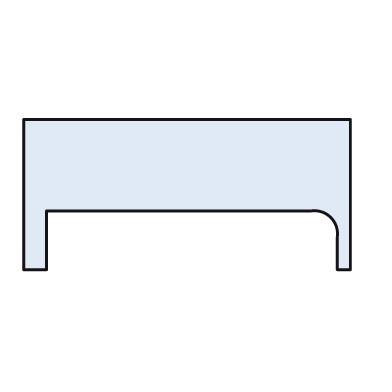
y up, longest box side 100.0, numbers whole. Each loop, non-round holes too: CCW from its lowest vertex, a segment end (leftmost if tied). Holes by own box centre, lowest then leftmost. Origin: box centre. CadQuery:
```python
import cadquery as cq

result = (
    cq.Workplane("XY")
    .moveTo(-50.0, -23.0)
    .lineTo(-43.0, -23.0)
    .lineTo(-43.0, -5.0)
    .lineTo(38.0, -5.0)
    .threePointArc((44.0, -7.0), (46.0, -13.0))
    .lineTo(46.0, -23.0)
    .lineTo(50.0, -23.0)
    .lineTo(50.0, 23.0)
    .lineTo(-50.0, 23.0)
    .close()
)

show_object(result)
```